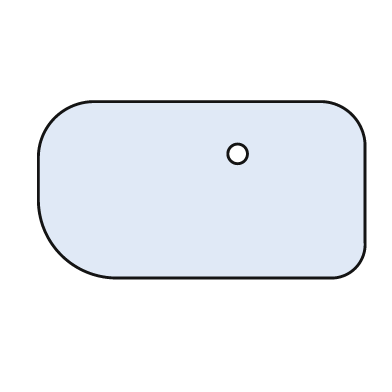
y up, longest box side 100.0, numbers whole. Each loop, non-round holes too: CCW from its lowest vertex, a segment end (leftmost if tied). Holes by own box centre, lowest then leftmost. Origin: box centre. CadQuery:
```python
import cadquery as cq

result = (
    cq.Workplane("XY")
    .moveTo(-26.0, -27.0)
    .lineTo(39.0, -27.0)
    .threePointArc((47.0, -24.0), (50.0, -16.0))
    .lineTo(50.0, 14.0)
    .threePointArc((46.0, 23.0), (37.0, 27.0))
    .lineTo(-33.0, 27.0)
    .threePointArc((-45.0, 22.0), (-50.0, 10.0))
    .lineTo(-50.0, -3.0)
    .threePointArc((-43.0, -20.0), (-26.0, -27.0))
    .close()
    .moveTo(11.0, 11.0)
    .circle(3.0)
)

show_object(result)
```